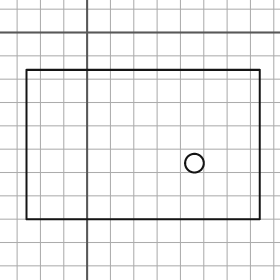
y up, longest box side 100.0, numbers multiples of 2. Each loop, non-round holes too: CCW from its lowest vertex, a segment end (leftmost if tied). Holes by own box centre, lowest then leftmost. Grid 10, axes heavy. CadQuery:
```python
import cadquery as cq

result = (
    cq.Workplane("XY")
    .moveTo(-26.0, -80.0)
    .lineTo(74.0, -80.0)
    .lineTo(74.0, -16.0)
    .lineTo(-26.0, -16.0)
    .close()
    .moveTo(46.0, -56.0)
    .circle(4.0)
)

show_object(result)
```